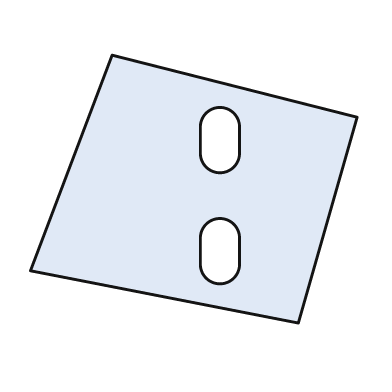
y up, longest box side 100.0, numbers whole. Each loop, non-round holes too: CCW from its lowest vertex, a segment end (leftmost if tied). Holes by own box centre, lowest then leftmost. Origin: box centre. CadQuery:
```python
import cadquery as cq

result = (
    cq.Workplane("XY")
    .moveTo(32.0, -41.0)
    .lineTo(50.0, 22.0)
    .lineTo(-25.0, 41.0)
    .lineTo(-50.0, -25.0)
    .close()
    .moveTo(2.0, -23.0)
    .threePointArc((8.0, -29.0), (14.0, -23.0))
    .lineTo(14.0, -15.0)
    .threePointArc((8.0, -9.0), (2.0, -15.0))
    .close()
    .moveTo(2.0, 11.0)
    .threePointArc((8.0, 5.0), (14.0, 11.0))
    .lineTo(14.0, 19.0)
    .threePointArc((8.0, 25.0), (2.0, 19.0))
    .close()
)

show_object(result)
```